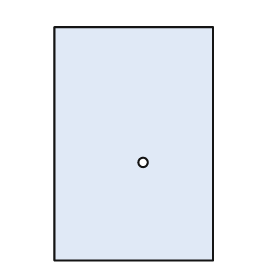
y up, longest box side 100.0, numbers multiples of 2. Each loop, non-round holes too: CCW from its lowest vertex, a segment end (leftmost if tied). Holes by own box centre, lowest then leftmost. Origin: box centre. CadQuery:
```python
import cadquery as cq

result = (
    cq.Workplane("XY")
    .moveTo(-34.0, -50.0)
    .lineTo(34.0, -50.0)
    .lineTo(34.0, 50.0)
    .lineTo(-34.0, 50.0)
    .close()
    .moveTo(4.0, -8.0)
    .circle(2.0)
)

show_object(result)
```